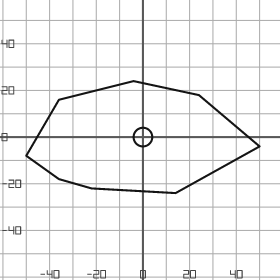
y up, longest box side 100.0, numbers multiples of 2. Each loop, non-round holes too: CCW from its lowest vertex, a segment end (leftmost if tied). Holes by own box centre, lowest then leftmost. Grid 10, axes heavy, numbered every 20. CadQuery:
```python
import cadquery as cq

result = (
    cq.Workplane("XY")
    .moveTo(14.0, -24.0)
    .lineTo(50.0, -4.0)
    .lineTo(24.0, 18.0)
    .lineTo(-4.0, 24.0)
    .lineTo(-36.0, 16.0)
    .lineTo(-50.0, -8.0)
    .lineTo(-36.0, -18.0)
    .lineTo(-22.0, -22.0)
    .close()
    .moveTo(0.0, 0.0)
    .circle(4.0)
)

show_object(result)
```